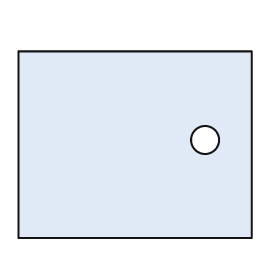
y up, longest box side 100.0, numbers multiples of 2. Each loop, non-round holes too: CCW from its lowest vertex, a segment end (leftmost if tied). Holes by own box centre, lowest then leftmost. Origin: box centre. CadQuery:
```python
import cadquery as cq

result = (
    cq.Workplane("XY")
    .moveTo(-50.0, -40.0)
    .lineTo(50.0, -40.0)
    .lineTo(50.0, 40.0)
    .lineTo(-50.0, 40.0)
    .close()
    .moveTo(30.0, 2.0)
    .circle(6.0)
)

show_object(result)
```